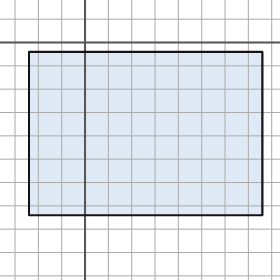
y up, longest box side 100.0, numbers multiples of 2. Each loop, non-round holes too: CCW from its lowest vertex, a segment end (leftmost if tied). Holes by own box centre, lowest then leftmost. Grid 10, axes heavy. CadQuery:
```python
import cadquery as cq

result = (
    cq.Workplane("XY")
    .moveTo(-24.0, -74.0)
    .lineTo(76.0, -74.0)
    .lineTo(76.0, -4.0)
    .lineTo(-24.0, -4.0)
    .close()
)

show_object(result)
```